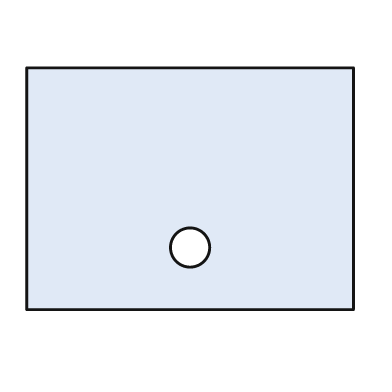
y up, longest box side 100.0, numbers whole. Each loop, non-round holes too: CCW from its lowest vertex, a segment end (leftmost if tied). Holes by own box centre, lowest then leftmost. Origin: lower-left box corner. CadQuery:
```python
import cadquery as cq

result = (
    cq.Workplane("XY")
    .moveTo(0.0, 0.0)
    .lineTo(100.0, 0.0)
    .lineTo(100.0, 74.0)
    .lineTo(0.0, 74.0)
    .close()
    .moveTo(50.0, 19.0)
    .circle(6.0)
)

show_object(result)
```